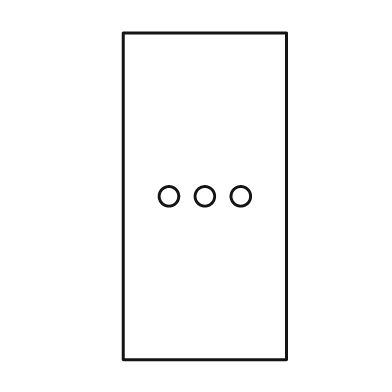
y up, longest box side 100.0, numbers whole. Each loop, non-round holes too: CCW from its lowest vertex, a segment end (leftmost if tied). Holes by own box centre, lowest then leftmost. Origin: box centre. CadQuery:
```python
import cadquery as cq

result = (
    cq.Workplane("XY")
    .moveTo(-25.0, -50.0)
    .lineTo(25.0, -50.0)
    .lineTo(25.0, 50.0)
    .lineTo(-25.0, 50.0)
    .close()
    .moveTo(-11.0, 0.0)
    .circle(3.0)
    .moveTo(0.0, 0.0)
    .circle(3.0)
    .moveTo(11.0, 0.0)
    .circle(3.0)
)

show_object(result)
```